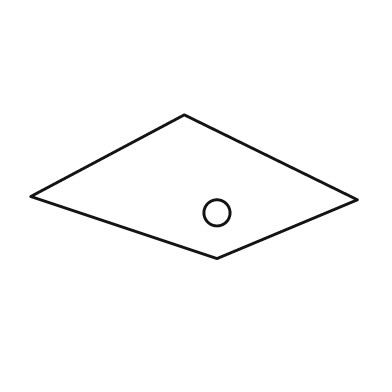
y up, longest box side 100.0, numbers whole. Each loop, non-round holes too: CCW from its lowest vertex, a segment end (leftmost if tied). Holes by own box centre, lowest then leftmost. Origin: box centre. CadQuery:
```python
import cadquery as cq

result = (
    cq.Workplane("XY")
    .moveTo(7.0, -22.0)
    .lineTo(50.0, -4.0)
    .lineTo(-3.0, 22.0)
    .lineTo(-50.0, -3.0)
    .close()
    .moveTo(7.0, -8.0)
    .circle(4.0)
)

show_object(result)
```